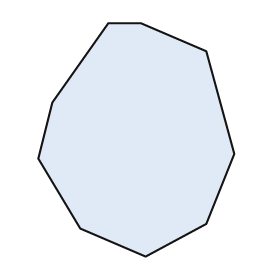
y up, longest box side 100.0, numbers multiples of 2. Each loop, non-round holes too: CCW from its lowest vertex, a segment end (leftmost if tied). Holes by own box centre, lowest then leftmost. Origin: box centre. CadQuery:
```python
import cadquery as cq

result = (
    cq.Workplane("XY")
    .moveTo(4.0, -50.0)
    .lineTo(30.0, -36.0)
    .lineTo(42.0, -6.0)
    .lineTo(30.0, 38.0)
    .lineTo(2.0, 50.0)
    .lineTo(-12.0, 50.0)
    .lineTo(-36.0, 16.0)
    .lineTo(-42.0, -8.0)
    .lineTo(-24.0, -38.0)
    .close()
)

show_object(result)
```